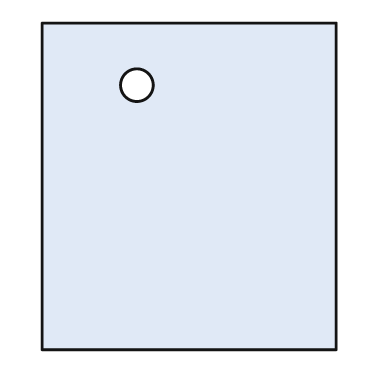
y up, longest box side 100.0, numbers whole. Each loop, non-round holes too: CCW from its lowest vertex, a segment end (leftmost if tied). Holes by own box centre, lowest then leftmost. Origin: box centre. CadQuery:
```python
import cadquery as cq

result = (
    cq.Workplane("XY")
    .moveTo(-45.0, -50.0)
    .lineTo(45.0, -50.0)
    .lineTo(45.0, 50.0)
    .lineTo(-45.0, 50.0)
    .close()
    .moveTo(-16.0, 31.0)
    .circle(5.0)
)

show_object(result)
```